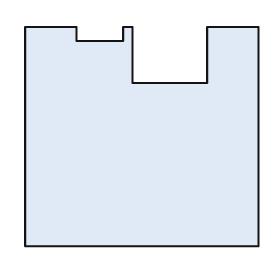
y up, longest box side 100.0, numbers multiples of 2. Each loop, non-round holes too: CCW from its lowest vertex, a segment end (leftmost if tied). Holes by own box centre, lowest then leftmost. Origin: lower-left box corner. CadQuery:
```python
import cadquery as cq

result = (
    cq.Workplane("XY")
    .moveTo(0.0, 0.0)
    .lineTo(100.0, 0.0)
    .lineTo(100.0, 94.0)
    .lineTo(78.0, 94.0)
    .lineTo(78.0, 70.0)
    .lineTo(46.0, 70.0)
    .lineTo(46.0, 94.0)
    .lineTo(42.0, 94.0)
    .lineTo(42.0, 88.0)
    .lineTo(22.0, 88.0)
    .lineTo(22.0, 94.0)
    .lineTo(0.0, 94.0)
    .close()
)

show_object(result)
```